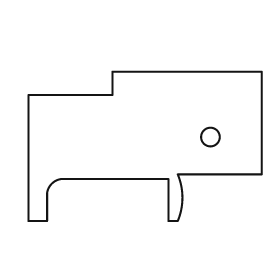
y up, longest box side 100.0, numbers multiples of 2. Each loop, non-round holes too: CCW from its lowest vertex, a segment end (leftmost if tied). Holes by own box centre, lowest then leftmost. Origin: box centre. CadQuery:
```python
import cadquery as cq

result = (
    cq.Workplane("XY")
    .moveTo(-50.0, -32.0)
    .lineTo(-42.0, -32.0)
    .lineTo(-42.0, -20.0)
    .threePointArc((-40.0, -16.0), (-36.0, -14.0))
    .lineTo(10.0, -14.0)
    .lineTo(10.0, -32.0)
    .lineTo(14.0, -32.0)
    .threePointArc((16.0, -22.0), (14.0, -12.0))
    .lineTo(50.0, -12.0)
    .lineTo(50.0, 32.0)
    .lineTo(-14.0, 32.0)
    .lineTo(-14.0, 22.0)
    .lineTo(-50.0, 22.0)
    .close()
    .moveTo(28.0, 4.0)
    .circle(4.0)
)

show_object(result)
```